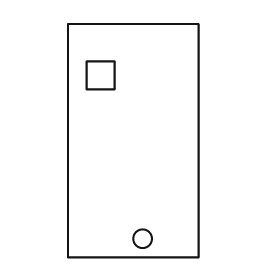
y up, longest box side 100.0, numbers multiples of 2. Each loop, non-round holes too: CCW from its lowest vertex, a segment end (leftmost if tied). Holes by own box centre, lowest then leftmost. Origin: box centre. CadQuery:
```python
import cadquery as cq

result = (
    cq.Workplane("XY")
    .moveTo(-28.0, -50.0)
    .lineTo(28.0, -50.0)
    .lineTo(28.0, 50.0)
    .lineTo(-28.0, 50.0)
    .close()
    .moveTo(4.0, -42.0)
    .circle(4.0)
    .moveTo(-20.0, 22.0)
    .lineTo(-8.0, 22.0)
    .lineTo(-8.0, 34.0)
    .lineTo(-20.0, 34.0)
    .close()
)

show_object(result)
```